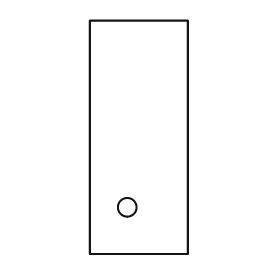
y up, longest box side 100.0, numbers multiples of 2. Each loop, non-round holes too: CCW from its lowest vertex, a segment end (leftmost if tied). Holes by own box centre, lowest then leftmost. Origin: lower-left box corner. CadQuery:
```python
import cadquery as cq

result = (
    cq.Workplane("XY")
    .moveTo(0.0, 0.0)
    .lineTo(42.0, 0.0)
    .lineTo(42.0, 100.0)
    .lineTo(0.0, 100.0)
    .close()
    .moveTo(16.0, 20.0)
    .circle(4.0)
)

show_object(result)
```